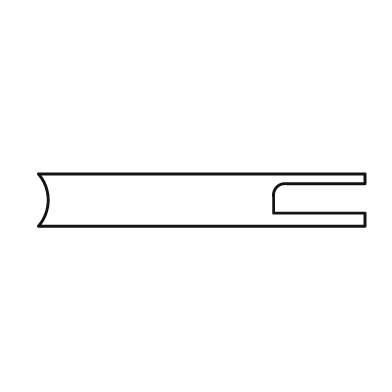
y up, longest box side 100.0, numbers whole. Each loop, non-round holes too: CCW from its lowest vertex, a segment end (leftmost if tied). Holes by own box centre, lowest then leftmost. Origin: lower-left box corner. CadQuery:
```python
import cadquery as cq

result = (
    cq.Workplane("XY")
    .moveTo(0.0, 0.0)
    .lineTo(100.0, 0.0)
    .lineTo(100.0, 4.0)
    .lineTo(72.0, 4.0)
    .lineTo(72.0, 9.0)
    .threePointArc((73.0, 12.0), (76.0, 13.0))
    .lineTo(100.0, 13.0)
    .lineTo(100.0, 16.0)
    .lineTo(0.0, 16.0)
    .threePointArc((3.0, 8.0), (0.0, 0.0))
    .close()
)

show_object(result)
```